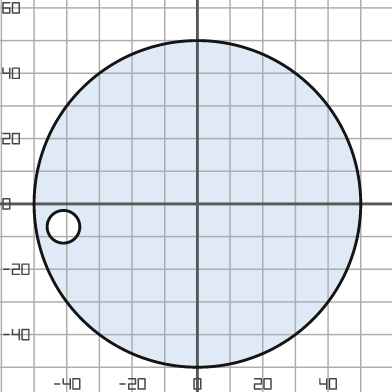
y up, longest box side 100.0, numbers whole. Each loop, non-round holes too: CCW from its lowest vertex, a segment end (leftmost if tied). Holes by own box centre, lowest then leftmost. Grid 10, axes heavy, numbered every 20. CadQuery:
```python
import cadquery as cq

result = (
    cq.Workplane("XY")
    .moveTo(0.0, 0.0)
    .circle(50.0)
    .moveTo(-41.0, -7.0)
    .circle(5.0)
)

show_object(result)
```